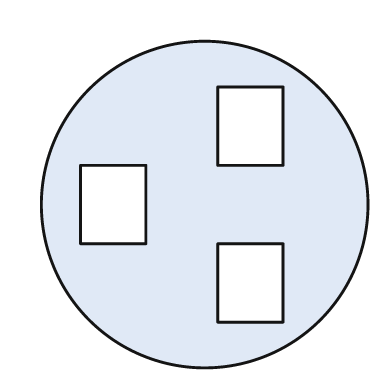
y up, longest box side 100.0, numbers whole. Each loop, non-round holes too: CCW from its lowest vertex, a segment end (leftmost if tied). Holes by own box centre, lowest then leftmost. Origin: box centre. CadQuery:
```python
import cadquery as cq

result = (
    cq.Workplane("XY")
    .moveTo(0.0, 0.0)
    .circle(50.0)
    .moveTo(4.0, -36.0)
    .lineTo(24.0, -36.0)
    .lineTo(24.0, -12.0)
    .lineTo(4.0, -12.0)
    .close()
    .moveTo(-38.0, -12.0)
    .lineTo(-18.0, -12.0)
    .lineTo(-18.0, 12.0)
    .lineTo(-38.0, 12.0)
    .close()
    .moveTo(4.0, 12.0)
    .lineTo(24.0, 12.0)
    .lineTo(24.0, 36.0)
    .lineTo(4.0, 36.0)
    .close()
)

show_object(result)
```